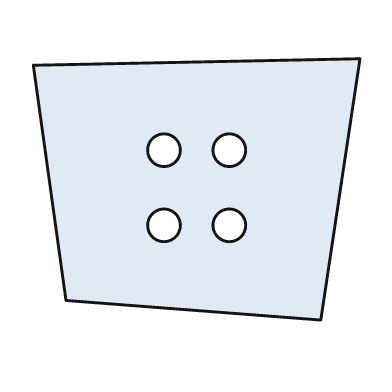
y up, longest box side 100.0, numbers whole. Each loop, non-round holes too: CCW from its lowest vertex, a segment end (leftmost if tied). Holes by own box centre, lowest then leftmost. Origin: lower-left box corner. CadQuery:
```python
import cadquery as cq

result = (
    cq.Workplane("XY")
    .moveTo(88.0, 0.0)
    .lineTo(100.0, 80.0)
    .lineTo(0.0, 78.0)
    .lineTo(10.0, 6.0)
    .close()
    .moveTo(40.0, 29.0)
    .circle(5.0)
    .moveTo(60.0, 29.0)
    .circle(5.0)
    .moveTo(40.0, 52.0)
    .circle(5.0)
    .moveTo(60.0, 52.0)
    .circle(5.0)
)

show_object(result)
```